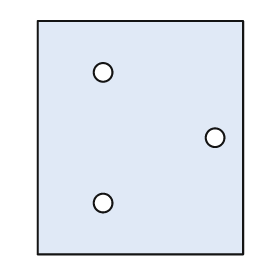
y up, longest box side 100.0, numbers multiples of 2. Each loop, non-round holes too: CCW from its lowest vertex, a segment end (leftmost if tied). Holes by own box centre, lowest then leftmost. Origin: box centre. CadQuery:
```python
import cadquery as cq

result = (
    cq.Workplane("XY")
    .moveTo(-44.0, -50.0)
    .lineTo(44.0, -50.0)
    .lineTo(44.0, 50.0)
    .lineTo(-44.0, 50.0)
    .close()
    .moveTo(-16.0, -28.0)
    .circle(4.0)
    .moveTo(32.0, 0.0)
    .circle(4.0)
    .moveTo(-16.0, 28.0)
    .circle(4.0)
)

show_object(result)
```